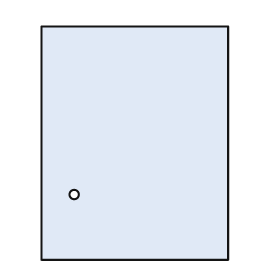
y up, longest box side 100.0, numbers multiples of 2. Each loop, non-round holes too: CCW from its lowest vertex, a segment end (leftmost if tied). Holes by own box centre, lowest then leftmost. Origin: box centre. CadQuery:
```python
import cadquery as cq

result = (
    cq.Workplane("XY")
    .moveTo(-40.0, -50.0)
    .lineTo(40.0, -50.0)
    .lineTo(40.0, 50.0)
    .lineTo(-40.0, 50.0)
    .close()
    .moveTo(-26.0, -22.0)
    .circle(2.0)
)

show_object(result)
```